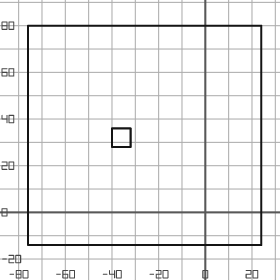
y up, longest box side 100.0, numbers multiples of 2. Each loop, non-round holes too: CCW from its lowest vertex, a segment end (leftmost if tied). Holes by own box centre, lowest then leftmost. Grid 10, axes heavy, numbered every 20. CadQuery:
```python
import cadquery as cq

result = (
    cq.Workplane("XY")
    .moveTo(-76.0, -14.0)
    .lineTo(24.0, -14.0)
    .lineTo(24.0, 80.0)
    .lineTo(-76.0, 80.0)
    .close()
    .moveTo(-40.0, 28.0)
    .lineTo(-32.0, 28.0)
    .lineTo(-32.0, 36.0)
    .lineTo(-40.0, 36.0)
    .close()
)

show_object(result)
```